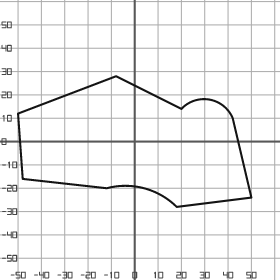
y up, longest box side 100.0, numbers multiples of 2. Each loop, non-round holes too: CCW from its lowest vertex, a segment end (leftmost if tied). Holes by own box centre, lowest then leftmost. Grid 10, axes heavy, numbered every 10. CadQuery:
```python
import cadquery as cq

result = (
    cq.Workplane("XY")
    .moveTo(18.0, -28.0)
    .lineTo(50.0, -24.0)
    .lineTo(42.0, 10.0)
    .threePointArc((32.0, 18.0), (20.0, 14.0))
    .lineTo(-8.0, 28.0)
    .lineTo(-50.0, 12.0)
    .lineTo(-48.0, -16.0)
    .lineTo(-12.0, -20.0)
    .threePointArc((4.0, -20.0), (18.0, -28.0))
    .close()
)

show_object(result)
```